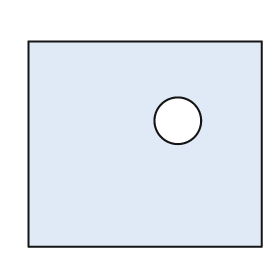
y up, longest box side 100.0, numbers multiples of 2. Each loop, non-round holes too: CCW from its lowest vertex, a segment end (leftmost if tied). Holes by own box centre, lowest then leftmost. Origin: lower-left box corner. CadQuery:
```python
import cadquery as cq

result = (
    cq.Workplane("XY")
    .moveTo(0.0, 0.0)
    .lineTo(100.0, 0.0)
    .lineTo(100.0, 88.0)
    .lineTo(0.0, 88.0)
    .close()
    .moveTo(64.0, 54.0)
    .circle(10.0)
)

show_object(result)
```